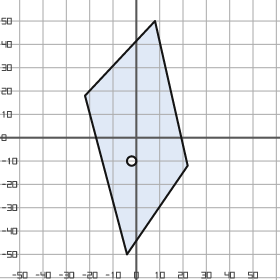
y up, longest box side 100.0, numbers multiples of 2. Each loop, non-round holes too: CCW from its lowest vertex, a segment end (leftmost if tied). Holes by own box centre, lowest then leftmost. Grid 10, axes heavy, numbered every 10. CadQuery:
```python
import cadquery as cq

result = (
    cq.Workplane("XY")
    .moveTo(-4.0, -50.0)
    .lineTo(22.0, -12.0)
    .lineTo(8.0, 50.0)
    .lineTo(-22.0, 18.0)
    .close()
    .moveTo(-2.0, -10.0)
    .circle(2.0)
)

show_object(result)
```